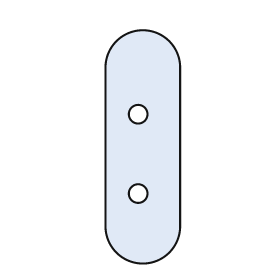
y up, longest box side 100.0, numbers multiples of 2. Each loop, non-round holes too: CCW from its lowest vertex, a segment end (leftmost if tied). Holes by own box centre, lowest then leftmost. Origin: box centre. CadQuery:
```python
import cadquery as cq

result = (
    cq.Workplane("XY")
    .moveTo(-16.0, -34.0)
    .threePointArc((0.0, -50.0), (16.0, -34.0))
    .lineTo(16.0, 34.0)
    .threePointArc((0.0, 50.0), (-16.0, 34.0))
    .close()
    .moveTo(-2.0, -20.0)
    .circle(4.0)
    .moveTo(-2.0, 14.0)
    .circle(4.0)
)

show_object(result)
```